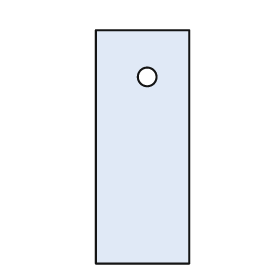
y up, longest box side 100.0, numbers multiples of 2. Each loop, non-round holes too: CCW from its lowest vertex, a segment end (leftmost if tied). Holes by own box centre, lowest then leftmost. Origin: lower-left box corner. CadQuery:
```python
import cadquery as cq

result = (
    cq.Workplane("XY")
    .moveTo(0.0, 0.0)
    .lineTo(40.0, 0.0)
    .lineTo(40.0, 100.0)
    .lineTo(0.0, 100.0)
    .close()
    .moveTo(22.0, 80.0)
    .circle(4.0)
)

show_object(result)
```